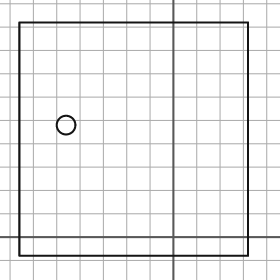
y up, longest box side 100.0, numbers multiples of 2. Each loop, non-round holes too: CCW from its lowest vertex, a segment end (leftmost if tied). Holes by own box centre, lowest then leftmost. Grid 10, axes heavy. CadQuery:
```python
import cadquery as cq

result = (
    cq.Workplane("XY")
    .moveTo(-66.0, -8.0)
    .lineTo(32.0, -8.0)
    .lineTo(32.0, 92.0)
    .lineTo(-66.0, 92.0)
    .close()
    .moveTo(-46.0, 48.0)
    .circle(4.0)
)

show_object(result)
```